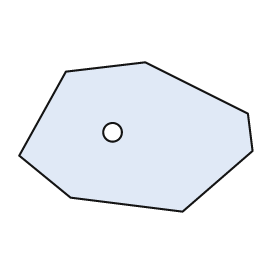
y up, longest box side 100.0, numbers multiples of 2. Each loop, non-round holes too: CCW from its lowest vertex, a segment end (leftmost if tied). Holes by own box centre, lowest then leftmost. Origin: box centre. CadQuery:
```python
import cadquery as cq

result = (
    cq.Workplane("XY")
    .moveTo(20.0, -32.0)
    .lineTo(50.0, -6.0)
    .lineTo(48.0, 10.0)
    .lineTo(4.0, 32.0)
    .lineTo(-30.0, 28.0)
    .lineTo(-50.0, -8.0)
    .lineTo(-28.0, -26.0)
    .close()
    .moveTo(-10.0, 2.0)
    .circle(4.0)
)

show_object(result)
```